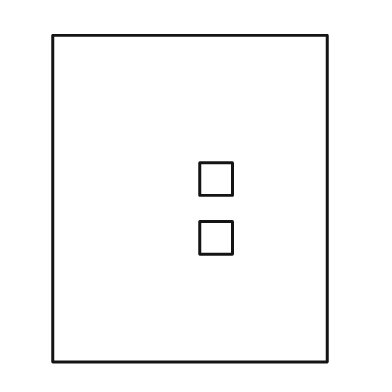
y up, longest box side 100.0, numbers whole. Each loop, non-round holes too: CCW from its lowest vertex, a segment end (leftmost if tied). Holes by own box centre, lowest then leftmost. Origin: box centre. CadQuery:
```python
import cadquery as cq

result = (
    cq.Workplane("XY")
    .moveTo(-42.0, -50.0)
    .lineTo(42.0, -50.0)
    .lineTo(42.0, 50.0)
    .lineTo(-42.0, 50.0)
    .close()
    .moveTo(3.0, -17.0)
    .lineTo(13.0, -17.0)
    .lineTo(13.0, -7.0)
    .lineTo(3.0, -7.0)
    .close()
    .moveTo(3.0, 1.0)
    .lineTo(13.0, 1.0)
    .lineTo(13.0, 11.0)
    .lineTo(3.0, 11.0)
    .close()
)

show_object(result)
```